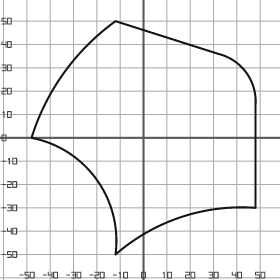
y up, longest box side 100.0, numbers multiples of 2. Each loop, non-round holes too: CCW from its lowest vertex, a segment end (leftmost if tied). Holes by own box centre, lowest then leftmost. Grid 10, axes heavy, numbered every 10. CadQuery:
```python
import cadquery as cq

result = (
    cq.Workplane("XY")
    .moveTo(-12.0, -50.0)
    .threePointArc((16.0, -34.0), (48.0, -30.0))
    .lineTo(48.0, 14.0)
    .threePointArc((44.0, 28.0), (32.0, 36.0))
    .lineTo(-12.0, 50.0)
    .threePointArc((-34.0, 28.0), (-48.0, 0.0))
    .threePointArc((-20.0, -18.0), (-12.0, -50.0))
    .close()
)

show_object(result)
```